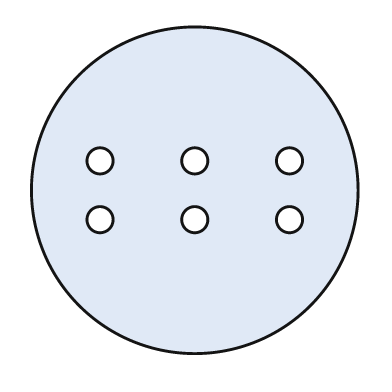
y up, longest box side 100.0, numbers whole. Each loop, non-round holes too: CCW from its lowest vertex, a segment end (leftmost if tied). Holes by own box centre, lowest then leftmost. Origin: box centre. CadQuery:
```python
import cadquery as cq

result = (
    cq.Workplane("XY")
    .moveTo(0.0, 0.0)
    .circle(50.0)
    .moveTo(-29.0, -9.0)
    .circle(4.0)
    .moveTo(0.0, -9.0)
    .circle(4.0)
    .moveTo(29.0, -9.0)
    .circle(4.0)
    .moveTo(-29.0, 9.0)
    .circle(4.0)
    .moveTo(0.0, 9.0)
    .circle(4.0)
    .moveTo(29.0, 9.0)
    .circle(4.0)
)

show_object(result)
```